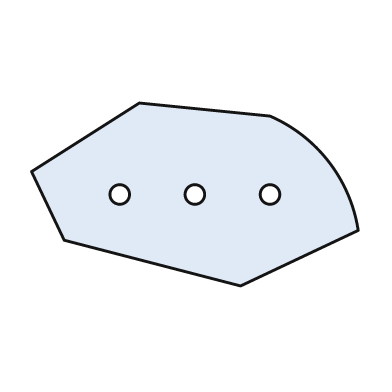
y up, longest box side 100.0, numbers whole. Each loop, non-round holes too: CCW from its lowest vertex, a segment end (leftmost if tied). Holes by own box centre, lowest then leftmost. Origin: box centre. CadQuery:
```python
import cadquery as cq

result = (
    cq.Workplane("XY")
    .moveTo(14.0, -28.0)
    .lineTo(50.0, -11.0)
    .threePointArc((41.0, 10.0), (23.0, 24.0))
    .lineTo(-17.0, 28.0)
    .lineTo(-50.0, 7.0)
    .lineTo(-40.0, -14.0)
    .close()
    .moveTo(-23.0, 0.0)
    .circle(3.0)
    .moveTo(0.0, 0.0)
    .circle(3.0)
    .moveTo(23.0, 0.0)
    .circle(3.0)
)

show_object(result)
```